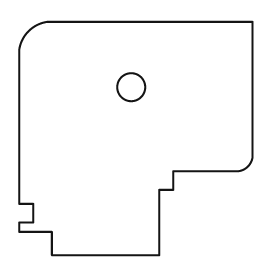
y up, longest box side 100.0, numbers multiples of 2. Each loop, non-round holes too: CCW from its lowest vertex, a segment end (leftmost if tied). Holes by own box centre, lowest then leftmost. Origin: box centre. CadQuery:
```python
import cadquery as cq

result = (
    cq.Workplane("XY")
    .moveTo(-36.0, -50.0)
    .lineTo(10.0, -50.0)
    .lineTo(10.0, -22.0)
    .lineTo(16.0, -22.0)
    .lineTo(16.0, -14.0)
    .lineTo(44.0, -14.0)
    .threePointArc((48.0, -12.0), (50.0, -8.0))
    .lineTo(50.0, 50.0)
    .lineTo(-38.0, 50.0)
    .threePointArc((-46.0, 46.0), (-50.0, 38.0))
    .lineTo(-50.0, -28.0)
    .lineTo(-44.0, -28.0)
    .lineTo(-44.0, -36.0)
    .lineTo(-50.0, -36.0)
    .lineTo(-50.0, -40.0)
    .lineTo(-36.0, -40.0)
    .close()
    .moveTo(-2.0, 22.0)
    .circle(6.0)
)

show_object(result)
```